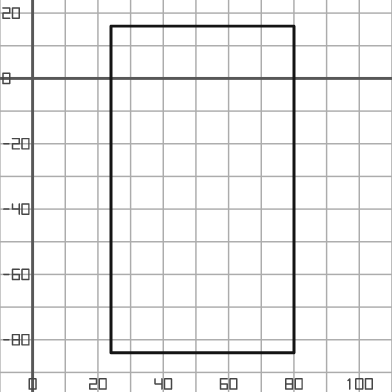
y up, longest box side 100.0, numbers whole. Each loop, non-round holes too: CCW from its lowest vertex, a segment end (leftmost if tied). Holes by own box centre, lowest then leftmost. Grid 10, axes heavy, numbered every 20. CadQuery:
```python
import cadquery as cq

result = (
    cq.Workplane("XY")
    .moveTo(24.0, -84.0)
    .lineTo(80.0, -84.0)
    .lineTo(80.0, 16.0)
    .lineTo(24.0, 16.0)
    .close()
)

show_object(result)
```